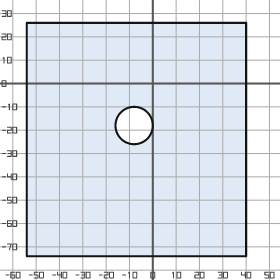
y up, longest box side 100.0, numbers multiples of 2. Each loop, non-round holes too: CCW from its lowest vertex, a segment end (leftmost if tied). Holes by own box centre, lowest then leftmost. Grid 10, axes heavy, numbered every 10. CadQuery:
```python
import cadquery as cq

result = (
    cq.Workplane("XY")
    .moveTo(-54.0, -74.0)
    .lineTo(40.0, -74.0)
    .lineTo(40.0, 26.0)
    .lineTo(-54.0, 26.0)
    .close()
    .moveTo(-8.0, -18.0)
    .circle(8.0)
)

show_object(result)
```